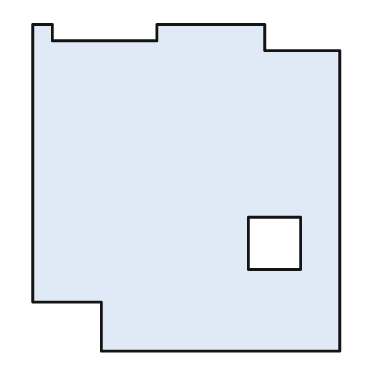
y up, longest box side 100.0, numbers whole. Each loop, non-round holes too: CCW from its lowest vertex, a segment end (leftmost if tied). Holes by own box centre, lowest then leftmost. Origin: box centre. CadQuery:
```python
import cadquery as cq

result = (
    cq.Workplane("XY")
    .moveTo(-26.0, -50.0)
    .lineTo(47.0, -50.0)
    .lineTo(47.0, 42.0)
    .lineTo(24.0, 42.0)
    .lineTo(24.0, 50.0)
    .lineTo(-9.0, 50.0)
    .lineTo(-9.0, 45.0)
    .lineTo(-41.0, 45.0)
    .lineTo(-41.0, 50.0)
    .lineTo(-47.0, 50.0)
    .lineTo(-47.0, -35.0)
    .lineTo(-26.0, -35.0)
    .close()
    .moveTo(19.0, -25.0)
    .lineTo(35.0, -25.0)
    .lineTo(35.0, -9.0)
    .lineTo(19.0, -9.0)
    .close()
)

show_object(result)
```